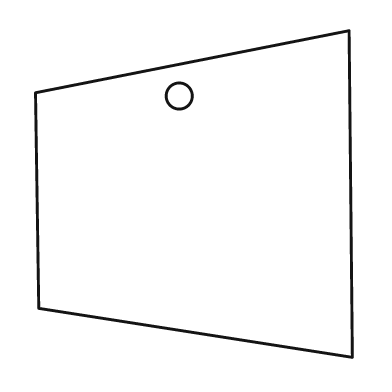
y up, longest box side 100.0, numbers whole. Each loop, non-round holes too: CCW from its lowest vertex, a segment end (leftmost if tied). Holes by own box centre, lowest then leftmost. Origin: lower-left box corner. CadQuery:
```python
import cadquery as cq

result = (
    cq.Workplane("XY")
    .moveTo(97.0, 0.0)
    .lineTo(96.0, 100.0)
    .lineTo(0.0, 81.0)
    .lineTo(1.0, 15.0)
    .close()
    .moveTo(44.0, 80.0)
    .circle(4.0)
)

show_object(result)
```